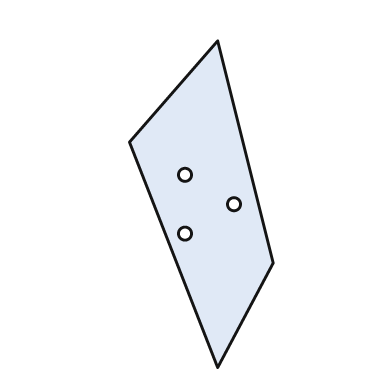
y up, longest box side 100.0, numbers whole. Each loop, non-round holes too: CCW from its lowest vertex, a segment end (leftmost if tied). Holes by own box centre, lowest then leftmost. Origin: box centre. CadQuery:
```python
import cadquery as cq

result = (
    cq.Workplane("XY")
    .moveTo(5.0, -50.0)
    .lineTo(22.0, -18.0)
    .lineTo(5.0, 50.0)
    .lineTo(-22.0, 19.0)
    .close()
    .moveTo(-5.0, -9.0)
    .circle(2.0)
    .moveTo(10.0, 0.0)
    .circle(2.0)
    .moveTo(-5.0, 9.0)
    .circle(2.0)
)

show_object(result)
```